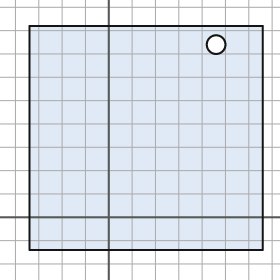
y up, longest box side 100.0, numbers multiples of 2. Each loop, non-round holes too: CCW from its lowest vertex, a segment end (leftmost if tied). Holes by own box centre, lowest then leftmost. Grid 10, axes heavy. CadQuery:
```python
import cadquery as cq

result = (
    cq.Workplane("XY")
    .moveTo(-34.0, -14.0)
    .lineTo(66.0, -14.0)
    .lineTo(66.0, 82.0)
    .lineTo(-34.0, 82.0)
    .close()
    .moveTo(46.0, 74.0)
    .circle(4.0)
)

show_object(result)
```